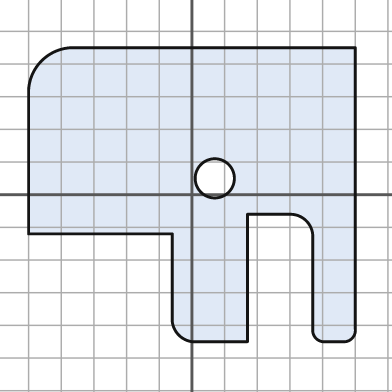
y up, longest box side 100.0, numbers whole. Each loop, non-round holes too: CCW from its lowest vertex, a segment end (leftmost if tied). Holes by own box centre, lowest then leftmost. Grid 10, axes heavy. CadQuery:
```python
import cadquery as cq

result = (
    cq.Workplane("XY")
    .moveTo(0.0, -45.0)
    .lineTo(17.0, -45.0)
    .lineTo(17.0, -6.0)
    .lineTo(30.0, -6.0)
    .threePointArc((35.0, -8.0), (37.0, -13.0))
    .lineTo(37.0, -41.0)
    .threePointArc((38.0, -44.0), (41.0, -45.0))
    .lineTo(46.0, -45.0)
    .threePointArc((49.0, -44.0), (50.0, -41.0))
    .lineTo(50.0, 45.0)
    .lineTo(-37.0, 45.0)
    .threePointArc((-46.0, 41.0), (-50.0, 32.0))
    .lineTo(-50.0, -12.0)
    .lineTo(-6.0, -12.0)
    .lineTo(-6.0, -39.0)
    .threePointArc((-4.0, -43.0), (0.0, -45.0))
    .close()
    .moveTo(7.0, 5.0)
    .circle(6.0)
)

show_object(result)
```